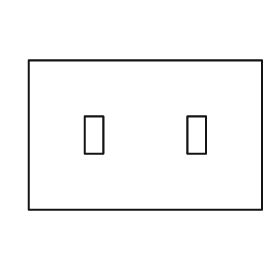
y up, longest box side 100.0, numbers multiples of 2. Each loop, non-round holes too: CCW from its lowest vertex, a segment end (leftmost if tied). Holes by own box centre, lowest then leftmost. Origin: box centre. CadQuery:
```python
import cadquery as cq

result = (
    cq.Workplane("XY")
    .moveTo(-50.0, -32.0)
    .lineTo(50.0, -32.0)
    .lineTo(50.0, 32.0)
    .lineTo(-50.0, 32.0)
    .close()
    .moveTo(-26.0, -8.0)
    .lineTo(-18.0, -8.0)
    .lineTo(-18.0, 8.0)
    .lineTo(-26.0, 8.0)
    .close()
    .moveTo(18.0, -8.0)
    .lineTo(26.0, -8.0)
    .lineTo(26.0, 8.0)
    .lineTo(18.0, 8.0)
    .close()
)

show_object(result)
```